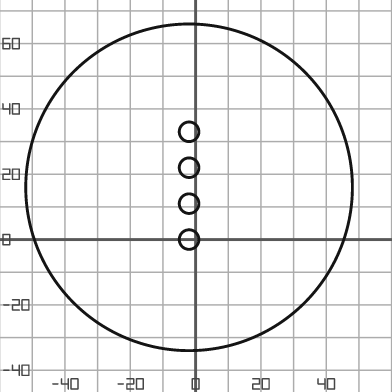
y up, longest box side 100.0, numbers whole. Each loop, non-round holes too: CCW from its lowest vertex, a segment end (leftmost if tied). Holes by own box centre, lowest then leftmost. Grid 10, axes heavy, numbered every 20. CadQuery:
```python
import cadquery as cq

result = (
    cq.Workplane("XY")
    .moveTo(-2.0, 16.0)
    .circle(50.0)
    .moveTo(-2.0, 0.0)
    .circle(3.0)
    .moveTo(-2.0, 11.0)
    .circle(3.0)
    .moveTo(-2.0, 22.0)
    .circle(3.0)
    .moveTo(-2.0, 33.0)
    .circle(3.0)
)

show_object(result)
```